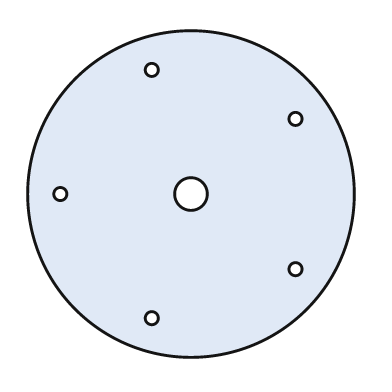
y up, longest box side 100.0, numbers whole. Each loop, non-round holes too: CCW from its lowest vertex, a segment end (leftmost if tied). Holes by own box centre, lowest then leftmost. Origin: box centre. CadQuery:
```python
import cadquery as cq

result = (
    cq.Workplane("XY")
    .moveTo(0.0, 0.0)
    .circle(50.0)
    .moveTo(-12.0, -38.0)
    .circle(2.0)
    .moveTo(32.0, -23.0)
    .circle(2.0)
    .moveTo(-40.0, 0.0)
    .circle(2.0)
    .moveTo(0.0, 0.0)
    .circle(5.0)
    .moveTo(32.0, 23.0)
    .circle(2.0)
    .moveTo(-12.0, 38.0)
    .circle(2.0)
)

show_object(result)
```